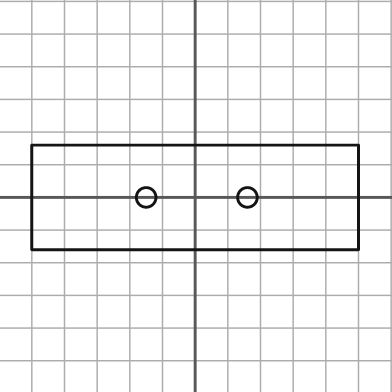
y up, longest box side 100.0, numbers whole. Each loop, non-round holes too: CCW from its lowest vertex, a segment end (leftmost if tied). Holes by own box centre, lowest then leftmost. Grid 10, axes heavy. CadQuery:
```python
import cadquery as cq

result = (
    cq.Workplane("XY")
    .moveTo(-50.0, -16.0)
    .lineTo(50.0, -16.0)
    .lineTo(50.0, 16.0)
    .lineTo(-50.0, 16.0)
    .close()
    .moveTo(-15.0, 0.0)
    .circle(3.0)
    .moveTo(16.0, 0.0)
    .circle(3.0)
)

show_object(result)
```